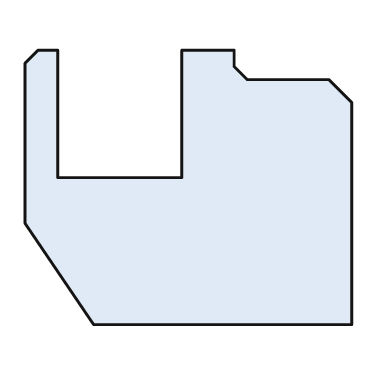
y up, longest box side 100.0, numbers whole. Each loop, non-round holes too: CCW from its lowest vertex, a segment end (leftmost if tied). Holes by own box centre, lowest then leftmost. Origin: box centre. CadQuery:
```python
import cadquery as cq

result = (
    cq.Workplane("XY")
    .moveTo(-29.0, -42.0)
    .lineTo(50.0, -42.0)
    .lineTo(50.0, 26.0)
    .lineTo(43.0, 33.0)
    .lineTo(18.0, 33.0)
    .lineTo(14.0, 37.0)
    .lineTo(14.0, 42.0)
    .lineTo(-2.0, 42.0)
    .lineTo(-2.0, 3.0)
    .lineTo(-40.0, 3.0)
    .lineTo(-40.0, 42.0)
    .lineTo(-46.0, 42.0)
    .lineTo(-50.0, 38.0)
    .lineTo(-50.0, -11.0)
    .close()
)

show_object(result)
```